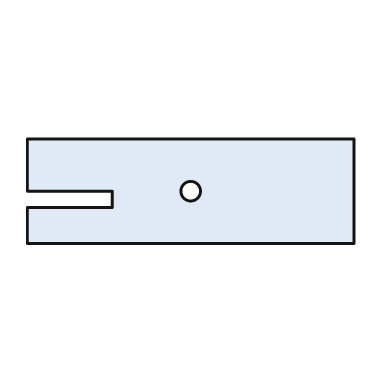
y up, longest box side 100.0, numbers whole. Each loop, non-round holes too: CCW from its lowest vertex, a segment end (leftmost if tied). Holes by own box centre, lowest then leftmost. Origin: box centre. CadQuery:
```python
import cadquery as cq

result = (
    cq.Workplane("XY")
    .moveTo(-50.0, -16.0)
    .lineTo(50.0, -16.0)
    .lineTo(50.0, 16.0)
    .lineTo(-50.0, 16.0)
    .lineTo(-50.0, 0.0)
    .lineTo(-24.0, 0.0)
    .lineTo(-24.0, -5.0)
    .lineTo(-50.0, -5.0)
    .close()
    .moveTo(0.0, 0.0)
    .circle(3.0)
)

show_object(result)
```